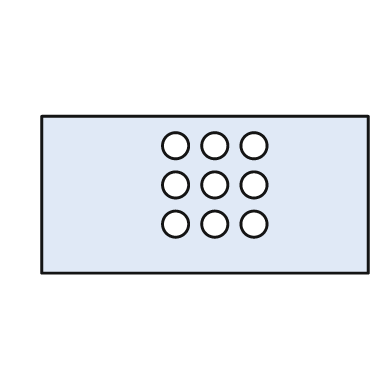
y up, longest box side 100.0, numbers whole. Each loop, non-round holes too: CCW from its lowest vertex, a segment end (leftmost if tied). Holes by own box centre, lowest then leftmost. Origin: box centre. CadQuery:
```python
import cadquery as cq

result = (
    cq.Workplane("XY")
    .moveTo(-50.0, -24.0)
    .lineTo(50.0, -24.0)
    .lineTo(50.0, 24.0)
    .lineTo(-50.0, 24.0)
    .close()
    .moveTo(-9.0, -9.0)
    .circle(4.0)
    .moveTo(3.0, -9.0)
    .circle(4.0)
    .moveTo(15.0, -9.0)
    .circle(4.0)
    .moveTo(-9.0, 3.0)
    .circle(4.0)
    .moveTo(3.0, 3.0)
    .circle(4.0)
    .moveTo(15.0, 3.0)
    .circle(4.0)
    .moveTo(-9.0, 15.0)
    .circle(4.0)
    .moveTo(3.0, 15.0)
    .circle(4.0)
    .moveTo(15.0, 15.0)
    .circle(4.0)
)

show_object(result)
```